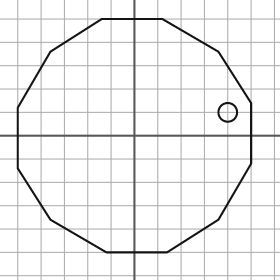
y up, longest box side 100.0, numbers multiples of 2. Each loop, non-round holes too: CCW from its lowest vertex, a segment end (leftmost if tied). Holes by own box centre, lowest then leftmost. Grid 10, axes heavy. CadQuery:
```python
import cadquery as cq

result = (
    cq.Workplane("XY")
    .moveTo(-12.0, -50.0)
    .lineTo(14.0, -50.0)
    .lineTo(36.0, -36.0)
    .lineTo(50.0, -12.0)
    .lineTo(50.0, 14.0)
    .lineTo(36.0, 36.0)
    .lineTo(12.0, 50.0)
    .lineTo(-14.0, 50.0)
    .lineTo(-36.0, 36.0)
    .lineTo(-50.0, 12.0)
    .lineTo(-50.0, -14.0)
    .lineTo(-36.0, -36.0)
    .close()
    .moveTo(40.0, 10.0)
    .circle(4.0)
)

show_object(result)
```